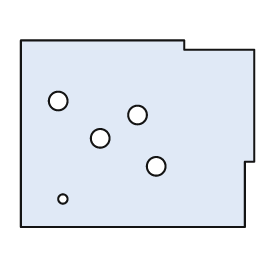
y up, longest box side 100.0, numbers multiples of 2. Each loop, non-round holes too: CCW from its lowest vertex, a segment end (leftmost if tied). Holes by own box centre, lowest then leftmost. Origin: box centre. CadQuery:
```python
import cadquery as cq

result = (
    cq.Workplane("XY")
    .moveTo(-50.0, -40.0)
    .lineTo(46.0, -40.0)
    .lineTo(46.0, -12.0)
    .lineTo(50.0, -12.0)
    .lineTo(50.0, 36.0)
    .lineTo(20.0, 36.0)
    .lineTo(20.0, 40.0)
    .lineTo(-50.0, 40.0)
    .close()
    .moveTo(-32.0, -28.0)
    .circle(2.0)
    .moveTo(8.0, -14.0)
    .circle(4.0)
    .moveTo(-16.0, -2.0)
    .circle(4.0)
    .moveTo(0.0, 8.0)
    .circle(4.0)
    .moveTo(-34.0, 14.0)
    .circle(4.0)
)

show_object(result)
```